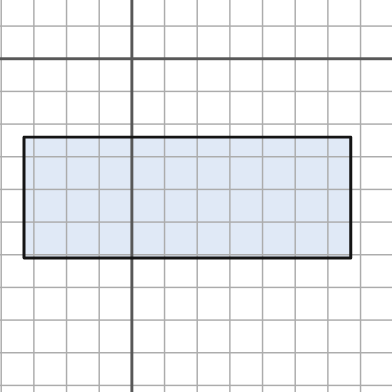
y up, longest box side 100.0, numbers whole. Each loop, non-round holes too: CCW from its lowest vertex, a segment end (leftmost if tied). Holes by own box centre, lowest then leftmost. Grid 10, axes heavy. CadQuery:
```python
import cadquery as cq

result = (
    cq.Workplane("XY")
    .moveTo(-33.0, -61.0)
    .lineTo(67.0, -61.0)
    .lineTo(67.0, -24.0)
    .lineTo(-33.0, -24.0)
    .close()
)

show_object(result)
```